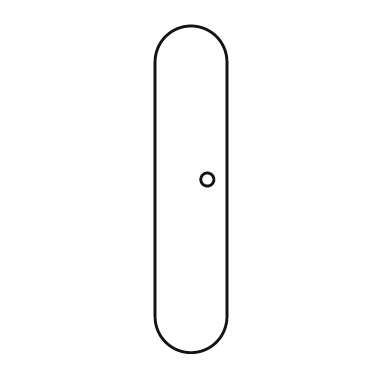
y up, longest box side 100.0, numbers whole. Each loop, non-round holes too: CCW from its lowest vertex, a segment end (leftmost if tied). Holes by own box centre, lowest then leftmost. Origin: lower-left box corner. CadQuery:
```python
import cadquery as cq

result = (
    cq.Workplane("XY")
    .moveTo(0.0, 11.0)
    .threePointArc((11.0, 0.0), (22.0, 11.0))
    .lineTo(22.0, 89.0)
    .threePointArc((11.0, 100.0), (0.0, 89.0))
    .close()
    .moveTo(16.0, 53.0)
    .circle(2.0)
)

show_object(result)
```